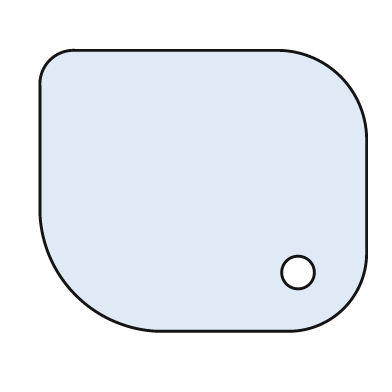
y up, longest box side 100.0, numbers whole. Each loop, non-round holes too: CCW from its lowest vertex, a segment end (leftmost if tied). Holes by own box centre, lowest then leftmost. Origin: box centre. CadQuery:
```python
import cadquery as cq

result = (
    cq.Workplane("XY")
    .moveTo(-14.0, -43.0)
    .lineTo(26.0, -43.0)
    .threePointArc((43.0, -36.0), (50.0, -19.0))
    .lineTo(50.0, 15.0)
    .threePointArc((42.0, 35.0), (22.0, 43.0))
    .lineTo(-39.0, 43.0)
    .threePointArc((-47.0, 40.0), (-50.0, 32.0))
    .lineTo(-50.0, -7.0)
    .threePointArc((-39.0, -32.0), (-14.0, -43.0))
    .close()
    .moveTo(29.0, -25.0)
    .circle(5.0)
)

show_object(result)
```